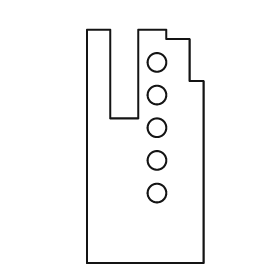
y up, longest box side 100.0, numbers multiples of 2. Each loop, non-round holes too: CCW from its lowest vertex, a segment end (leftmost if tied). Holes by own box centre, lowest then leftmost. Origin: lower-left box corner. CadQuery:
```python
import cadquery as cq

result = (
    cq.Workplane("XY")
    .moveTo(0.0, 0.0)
    .lineTo(50.0, 0.0)
    .lineTo(50.0, 78.0)
    .lineTo(44.0, 78.0)
    .lineTo(44.0, 96.0)
    .lineTo(34.0, 96.0)
    .lineTo(34.0, 100.0)
    .lineTo(22.0, 100.0)
    .lineTo(22.0, 62.0)
    .lineTo(10.0, 62.0)
    .lineTo(10.0, 100.0)
    .lineTo(0.0, 100.0)
    .close()
    .moveTo(30.0, 30.0)
    .circle(4.0)
    .moveTo(30.0, 44.0)
    .circle(4.0)
    .moveTo(30.0, 58.0)
    .circle(4.0)
    .moveTo(30.0, 72.0)
    .circle(4.0)
    .moveTo(30.0, 86.0)
    .circle(4.0)
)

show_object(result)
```